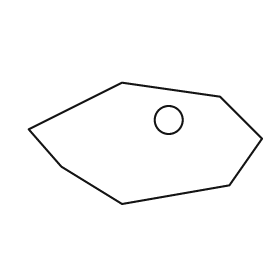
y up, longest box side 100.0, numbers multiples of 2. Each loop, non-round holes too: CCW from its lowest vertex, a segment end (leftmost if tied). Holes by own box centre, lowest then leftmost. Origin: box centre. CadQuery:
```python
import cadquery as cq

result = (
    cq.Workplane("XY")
    .moveTo(-10.0, -26.0)
    .lineTo(36.0, -18.0)
    .lineTo(50.0, 2.0)
    .lineTo(32.0, 20.0)
    .lineTo(-10.0, 26.0)
    .lineTo(-50.0, 6.0)
    .lineTo(-36.0, -10.0)
    .close()
    .moveTo(10.0, 10.0)
    .circle(6.0)
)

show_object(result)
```